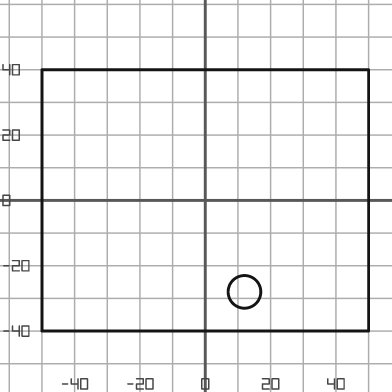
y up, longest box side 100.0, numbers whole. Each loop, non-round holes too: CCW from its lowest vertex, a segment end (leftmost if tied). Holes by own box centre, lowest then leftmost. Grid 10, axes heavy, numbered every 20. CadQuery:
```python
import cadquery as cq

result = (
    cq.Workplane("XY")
    .moveTo(-50.0, -40.0)
    .lineTo(50.0, -40.0)
    .lineTo(50.0, 40.0)
    .lineTo(-50.0, 40.0)
    .close()
    .moveTo(12.0, -28.0)
    .circle(5.0)
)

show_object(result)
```